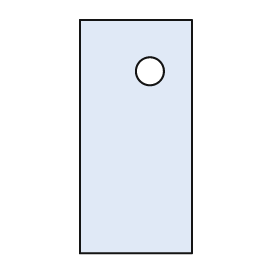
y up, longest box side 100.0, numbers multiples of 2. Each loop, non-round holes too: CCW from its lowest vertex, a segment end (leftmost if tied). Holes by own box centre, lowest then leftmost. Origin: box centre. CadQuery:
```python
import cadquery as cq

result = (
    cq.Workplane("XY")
    .moveTo(-24.0, -50.0)
    .lineTo(24.0, -50.0)
    .lineTo(24.0, 50.0)
    .lineTo(-24.0, 50.0)
    .close()
    .moveTo(6.0, 28.0)
    .circle(6.0)
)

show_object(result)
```